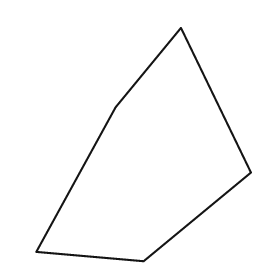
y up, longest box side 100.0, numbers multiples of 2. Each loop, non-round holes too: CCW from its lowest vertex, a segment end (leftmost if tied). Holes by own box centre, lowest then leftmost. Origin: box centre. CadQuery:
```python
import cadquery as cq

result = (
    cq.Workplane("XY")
    .moveTo(0.0, -50.0)
    .lineTo(46.0, -12.0)
    .lineTo(16.0, 50.0)
    .lineTo(-12.0, 16.0)
    .lineTo(-46.0, -46.0)
    .close()
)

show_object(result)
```